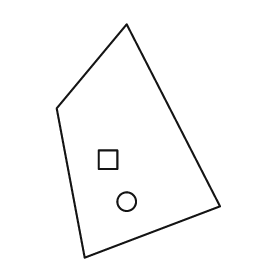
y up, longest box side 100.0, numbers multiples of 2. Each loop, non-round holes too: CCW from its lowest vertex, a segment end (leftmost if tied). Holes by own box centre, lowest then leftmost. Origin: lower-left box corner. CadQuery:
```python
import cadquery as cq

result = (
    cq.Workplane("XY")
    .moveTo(12.0, 0.0)
    .lineTo(70.0, 22.0)
    .lineTo(30.0, 100.0)
    .lineTo(0.0, 64.0)
    .close()
    .moveTo(30.0, 24.0)
    .circle(4.0)
    .moveTo(18.0, 38.0)
    .lineTo(26.0, 38.0)
    .lineTo(26.0, 46.0)
    .lineTo(18.0, 46.0)
    .close()
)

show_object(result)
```